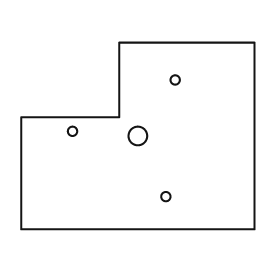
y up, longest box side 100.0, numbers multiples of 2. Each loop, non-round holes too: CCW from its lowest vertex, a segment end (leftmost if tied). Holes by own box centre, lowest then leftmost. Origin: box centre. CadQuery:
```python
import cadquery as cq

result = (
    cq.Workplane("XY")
    .moveTo(-50.0, -40.0)
    .lineTo(50.0, -40.0)
    .lineTo(50.0, 40.0)
    .lineTo(-8.0, 40.0)
    .lineTo(-8.0, 8.0)
    .lineTo(-50.0, 8.0)
    .close()
    .moveTo(12.0, -26.0)
    .circle(2.0)
    .moveTo(0.0, 0.0)
    .circle(4.0)
    .moveTo(-28.0, 2.0)
    .circle(2.0)
    .moveTo(16.0, 24.0)
    .circle(2.0)
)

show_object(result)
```